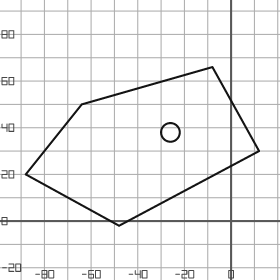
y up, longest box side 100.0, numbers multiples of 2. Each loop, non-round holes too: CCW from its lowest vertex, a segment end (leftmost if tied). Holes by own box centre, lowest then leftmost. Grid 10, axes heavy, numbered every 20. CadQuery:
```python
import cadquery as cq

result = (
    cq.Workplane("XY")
    .moveTo(-48.0, -2.0)
    .lineTo(12.0, 30.0)
    .lineTo(-8.0, 66.0)
    .lineTo(-64.0, 50.0)
    .lineTo(-88.0, 20.0)
    .close()
    .moveTo(-26.0, 38.0)
    .circle(4.0)
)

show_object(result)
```